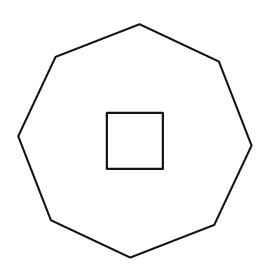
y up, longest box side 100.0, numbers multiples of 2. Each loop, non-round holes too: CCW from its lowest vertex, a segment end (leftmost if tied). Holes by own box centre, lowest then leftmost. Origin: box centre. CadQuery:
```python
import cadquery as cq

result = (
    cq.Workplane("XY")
    .moveTo(-2.0, -50.0)
    .lineTo(34.0, -36.0)
    .lineTo(50.0, -2.0)
    .lineTo(36.0, 34.0)
    .lineTo(2.0, 50.0)
    .lineTo(-34.0, 36.0)
    .lineTo(-50.0, 2.0)
    .lineTo(-36.0, -34.0)
    .close()
    .moveTo(-12.0, -12.0)
    .lineTo(12.0, -12.0)
    .lineTo(12.0, 12.0)
    .lineTo(-12.0, 12.0)
    .close()
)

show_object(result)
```